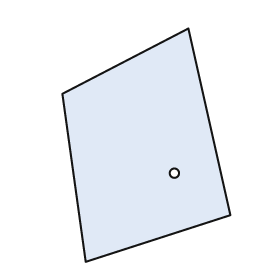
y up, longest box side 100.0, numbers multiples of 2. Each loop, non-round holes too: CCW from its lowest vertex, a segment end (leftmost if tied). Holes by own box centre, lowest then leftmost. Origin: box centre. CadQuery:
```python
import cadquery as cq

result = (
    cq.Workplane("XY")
    .moveTo(-26.0, -50.0)
    .lineTo(36.0, -30.0)
    .lineTo(18.0, 50.0)
    .lineTo(-36.0, 22.0)
    .close()
    .moveTo(12.0, -12.0)
    .circle(2.0)
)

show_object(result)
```